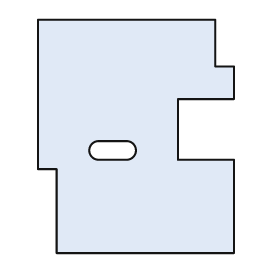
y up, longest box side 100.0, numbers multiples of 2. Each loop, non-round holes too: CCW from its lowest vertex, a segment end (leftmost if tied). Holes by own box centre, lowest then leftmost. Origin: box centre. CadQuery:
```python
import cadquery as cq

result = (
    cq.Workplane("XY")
    .moveTo(-34.0, -50.0)
    .lineTo(42.0, -50.0)
    .lineTo(42.0, -10.0)
    .lineTo(18.0, -10.0)
    .lineTo(18.0, 16.0)
    .lineTo(42.0, 16.0)
    .lineTo(42.0, 30.0)
    .lineTo(34.0, 30.0)
    .lineTo(34.0, 50.0)
    .lineTo(-42.0, 50.0)
    .lineTo(-42.0, -14.0)
    .lineTo(-34.0, -14.0)
    .close()
    .moveTo(-16.0, -10.0)
    .lineTo(-4.0, -10.0)
    .threePointArc((0.0, -6.0), (-4.0, -2.0))
    .lineTo(-16.0, -2.0)
    .threePointArc((-20.0, -6.0), (-16.0, -10.0))
    .close()
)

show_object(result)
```